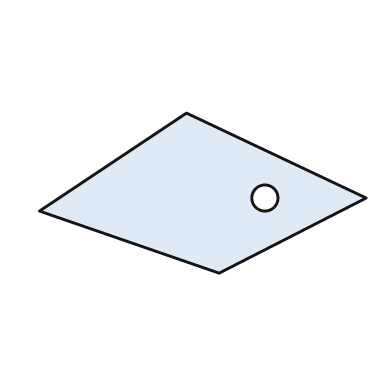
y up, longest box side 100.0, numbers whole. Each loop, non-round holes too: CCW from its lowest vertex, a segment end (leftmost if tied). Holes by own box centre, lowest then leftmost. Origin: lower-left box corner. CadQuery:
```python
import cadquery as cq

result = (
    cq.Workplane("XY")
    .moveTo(55.0, 0.0)
    .lineTo(100.0, 23.0)
    .lineTo(45.0, 49.0)
    .lineTo(0.0, 19.0)
    .close()
    .moveTo(69.0, 23.0)
    .circle(4.0)
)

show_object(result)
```